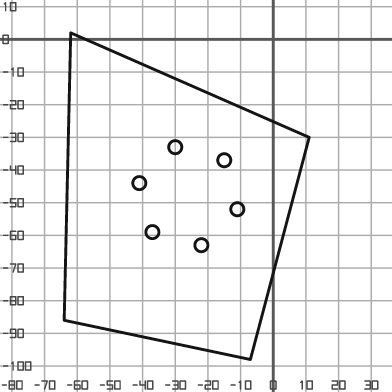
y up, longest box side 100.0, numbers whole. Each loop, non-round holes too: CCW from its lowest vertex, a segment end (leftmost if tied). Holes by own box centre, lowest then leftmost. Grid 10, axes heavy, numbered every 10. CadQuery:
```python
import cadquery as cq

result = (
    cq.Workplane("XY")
    .moveTo(-7.0, -98.0)
    .lineTo(11.0, -30.0)
    .lineTo(-62.0, 2.0)
    .lineTo(-64.0, -86.0)
    .close()
    .moveTo(-22.0, -63.0)
    .circle(2.0)
    .moveTo(-37.0, -59.0)
    .circle(2.0)
    .moveTo(-11.0, -52.0)
    .circle(2.0)
    .moveTo(-41.0, -44.0)
    .circle(2.0)
    .moveTo(-15.0, -37.0)
    .circle(2.0)
    .moveTo(-30.0, -33.0)
    .circle(2.0)
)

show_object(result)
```